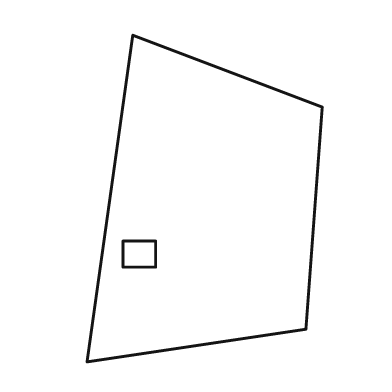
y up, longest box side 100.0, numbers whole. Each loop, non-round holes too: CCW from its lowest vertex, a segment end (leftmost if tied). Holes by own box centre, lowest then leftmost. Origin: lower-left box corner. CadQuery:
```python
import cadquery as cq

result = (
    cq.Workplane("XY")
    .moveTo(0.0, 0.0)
    .lineTo(67.0, 10.0)
    .lineTo(72.0, 78.0)
    .lineTo(14.0, 100.0)
    .close()
    .moveTo(11.0, 29.0)
    .lineTo(21.0, 29.0)
    .lineTo(21.0, 37.0)
    .lineTo(11.0, 37.0)
    .close()
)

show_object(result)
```